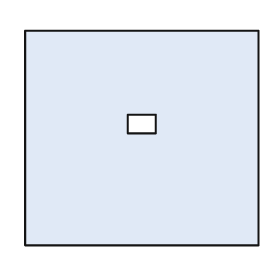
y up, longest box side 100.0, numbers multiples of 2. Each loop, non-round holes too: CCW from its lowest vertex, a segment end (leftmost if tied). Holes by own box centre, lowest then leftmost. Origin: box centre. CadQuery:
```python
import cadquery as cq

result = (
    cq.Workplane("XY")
    .moveTo(-50.0, -46.0)
    .lineTo(50.0, -46.0)
    .lineTo(50.0, 46.0)
    .lineTo(-50.0, 46.0)
    .close()
    .moveTo(-6.0, 2.0)
    .lineTo(6.0, 2.0)
    .lineTo(6.0, 10.0)
    .lineTo(-6.0, 10.0)
    .close()
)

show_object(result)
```